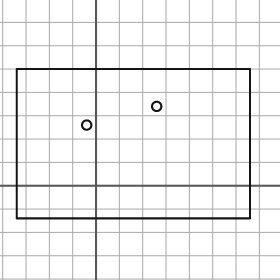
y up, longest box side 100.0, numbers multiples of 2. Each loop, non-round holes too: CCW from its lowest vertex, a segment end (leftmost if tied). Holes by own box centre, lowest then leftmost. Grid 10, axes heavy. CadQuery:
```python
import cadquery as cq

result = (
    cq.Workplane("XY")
    .moveTo(-34.0, -14.0)
    .lineTo(66.0, -14.0)
    .lineTo(66.0, 50.0)
    .lineTo(-34.0, 50.0)
    .close()
    .moveTo(-4.0, 26.0)
    .circle(2.0)
    .moveTo(26.0, 34.0)
    .circle(2.0)
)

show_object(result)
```